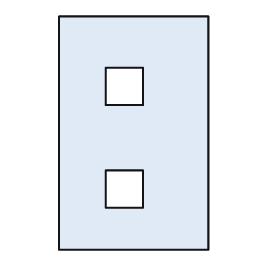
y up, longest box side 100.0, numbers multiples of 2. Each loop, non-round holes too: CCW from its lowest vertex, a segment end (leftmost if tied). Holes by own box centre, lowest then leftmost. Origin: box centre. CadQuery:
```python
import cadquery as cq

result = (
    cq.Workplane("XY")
    .moveTo(-32.0, -50.0)
    .lineTo(32.0, -50.0)
    .lineTo(32.0, 50.0)
    .lineTo(-32.0, 50.0)
    .close()
    .moveTo(-12.0, -32.0)
    .lineTo(4.0, -32.0)
    .lineTo(4.0, -16.0)
    .lineTo(-12.0, -16.0)
    .close()
    .moveTo(-12.0, 12.0)
    .lineTo(4.0, 12.0)
    .lineTo(4.0, 28.0)
    .lineTo(-12.0, 28.0)
    .close()
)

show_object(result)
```